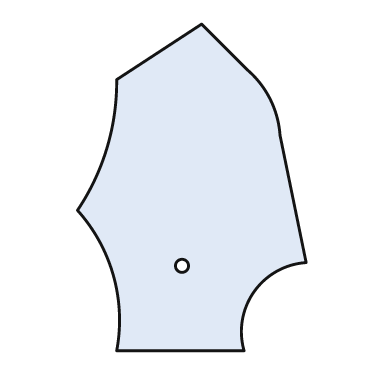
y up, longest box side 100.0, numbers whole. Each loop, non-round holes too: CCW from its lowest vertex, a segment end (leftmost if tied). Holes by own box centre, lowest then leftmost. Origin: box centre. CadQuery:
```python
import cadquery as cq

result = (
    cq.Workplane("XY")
    .moveTo(-23.0, -50.0)
    .lineTo(16.0, -50.0)
    .threePointArc((19.0, -32.0), (35.0, -23.0))
    .lineTo(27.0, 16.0)
    .threePointArc((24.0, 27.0), (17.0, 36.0))
    .lineTo(3.0, 50.0)
    .lineTo(-23.0, 33.0)
    .threePointArc((-26.0, 12.0), (-35.0, -7.0))
    .threePointArc((-24.0, -27.0), (-23.0, -50.0))
    .close()
    .moveTo(-3.0, -24.0)
    .circle(2.0)
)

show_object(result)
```